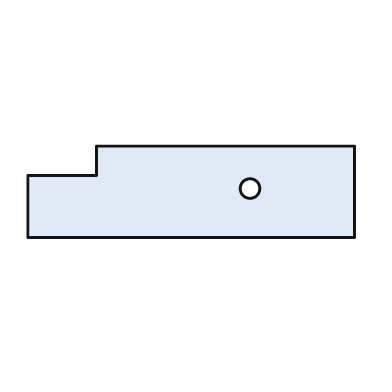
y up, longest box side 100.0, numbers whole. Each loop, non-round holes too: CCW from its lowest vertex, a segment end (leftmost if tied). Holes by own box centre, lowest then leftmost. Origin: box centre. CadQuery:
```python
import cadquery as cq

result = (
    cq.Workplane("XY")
    .moveTo(-50.0, -14.0)
    .lineTo(50.0, -14.0)
    .lineTo(50.0, 14.0)
    .lineTo(-29.0, 14.0)
    .lineTo(-29.0, 5.0)
    .lineTo(-50.0, 5.0)
    .close()
    .moveTo(18.0, 1.0)
    .circle(3.0)
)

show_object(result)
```